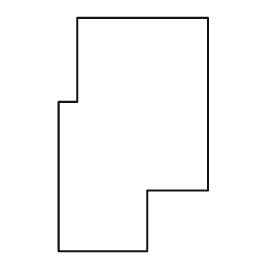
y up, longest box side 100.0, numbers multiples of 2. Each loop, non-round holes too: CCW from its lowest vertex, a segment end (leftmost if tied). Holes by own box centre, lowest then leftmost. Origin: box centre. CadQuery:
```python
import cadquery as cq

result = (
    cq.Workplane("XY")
    .moveTo(-32.0, -50.0)
    .lineTo(6.0, -50.0)
    .lineTo(6.0, -24.0)
    .lineTo(32.0, -24.0)
    .lineTo(32.0, 50.0)
    .lineTo(-24.0, 50.0)
    .lineTo(-24.0, 14.0)
    .lineTo(-32.0, 14.0)
    .close()
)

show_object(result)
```